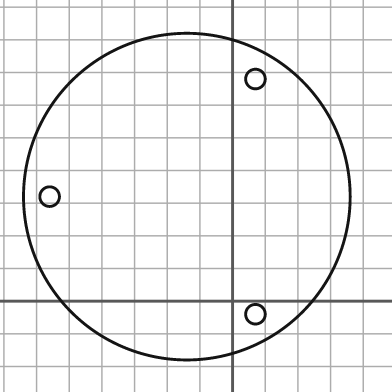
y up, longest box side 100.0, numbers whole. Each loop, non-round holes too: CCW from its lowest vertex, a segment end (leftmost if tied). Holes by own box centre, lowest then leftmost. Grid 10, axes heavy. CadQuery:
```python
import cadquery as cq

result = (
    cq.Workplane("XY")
    .moveTo(-14.0, 32.0)
    .circle(50.0)
    .moveTo(7.0, -4.0)
    .circle(3.0)
    .moveTo(-56.0, 32.0)
    .circle(3.0)
    .moveTo(7.0, 68.0)
    .circle(3.0)
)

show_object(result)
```